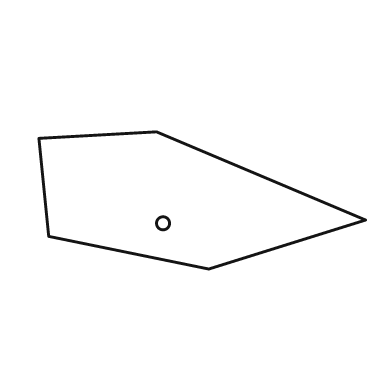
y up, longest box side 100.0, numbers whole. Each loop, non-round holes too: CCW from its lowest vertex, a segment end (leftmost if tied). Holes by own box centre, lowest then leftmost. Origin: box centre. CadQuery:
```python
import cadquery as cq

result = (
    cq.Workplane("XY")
    .moveTo(2.0, -21.0)
    .lineTo(50.0, -6.0)
    .lineTo(-14.0, 21.0)
    .lineTo(-50.0, 19.0)
    .lineTo(-47.0, -11.0)
    .close()
    .moveTo(-12.0, -7.0)
    .circle(2.0)
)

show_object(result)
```